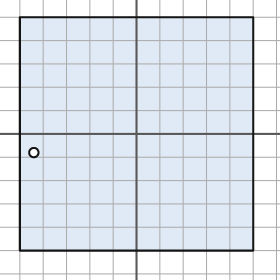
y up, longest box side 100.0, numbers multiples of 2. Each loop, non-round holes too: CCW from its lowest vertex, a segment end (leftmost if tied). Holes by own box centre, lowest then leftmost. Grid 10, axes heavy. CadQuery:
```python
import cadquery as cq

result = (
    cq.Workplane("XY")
    .moveTo(-50.0, -50.0)
    .lineTo(50.0, -50.0)
    .lineTo(50.0, 50.0)
    .lineTo(-50.0, 50.0)
    .close()
    .moveTo(-44.0, -8.0)
    .circle(2.0)
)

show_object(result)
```